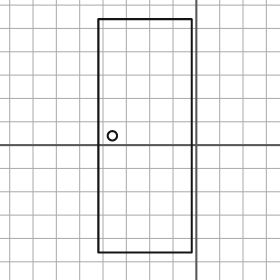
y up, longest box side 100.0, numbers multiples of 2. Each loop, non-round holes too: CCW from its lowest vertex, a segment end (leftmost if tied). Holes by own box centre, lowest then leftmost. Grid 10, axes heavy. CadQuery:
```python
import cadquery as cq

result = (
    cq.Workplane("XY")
    .moveTo(-42.0, -46.0)
    .lineTo(-2.0, -46.0)
    .lineTo(-2.0, 54.0)
    .lineTo(-42.0, 54.0)
    .close()
    .moveTo(-36.0, 4.0)
    .circle(2.0)
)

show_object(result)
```